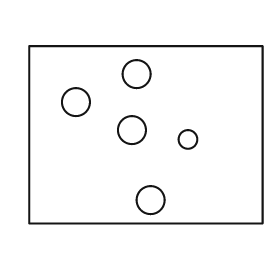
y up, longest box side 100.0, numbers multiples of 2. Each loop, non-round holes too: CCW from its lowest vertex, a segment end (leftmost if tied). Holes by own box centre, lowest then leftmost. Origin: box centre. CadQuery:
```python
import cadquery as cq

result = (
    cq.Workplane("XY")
    .moveTo(-50.0, -38.0)
    .lineTo(50.0, -38.0)
    .lineTo(50.0, 38.0)
    .lineTo(-50.0, 38.0)
    .close()
    .moveTo(2.0, -28.0)
    .circle(6.0)
    .moveTo(18.0, -2.0)
    .circle(4.0)
    .moveTo(-6.0, 2.0)
    .circle(6.0)
    .moveTo(-30.0, 14.0)
    .circle(6.0)
    .moveTo(-4.0, 26.0)
    .circle(6.0)
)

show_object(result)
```